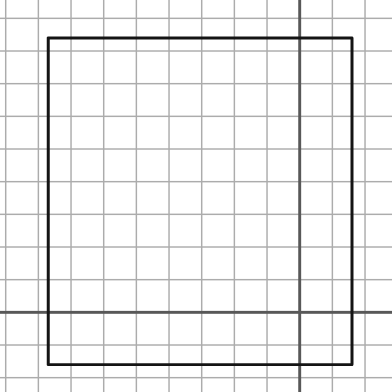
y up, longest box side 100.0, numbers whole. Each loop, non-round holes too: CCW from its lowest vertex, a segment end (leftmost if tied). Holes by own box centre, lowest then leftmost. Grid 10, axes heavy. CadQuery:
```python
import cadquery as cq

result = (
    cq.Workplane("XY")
    .moveTo(-77.0, -16.0)
    .lineTo(16.0, -16.0)
    .lineTo(16.0, 84.0)
    .lineTo(-77.0, 84.0)
    .close()
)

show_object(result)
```